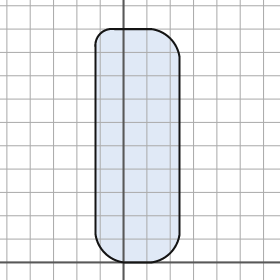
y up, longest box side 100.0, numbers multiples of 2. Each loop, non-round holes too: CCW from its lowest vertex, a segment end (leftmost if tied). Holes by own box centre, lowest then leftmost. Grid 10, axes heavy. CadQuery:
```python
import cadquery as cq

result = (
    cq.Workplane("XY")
    .moveTo(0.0, 0.0)
    .lineTo(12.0, 0.0)
    .threePointArc((20.0, 4.0), (24.0, 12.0))
    .lineTo(24.0, 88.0)
    .threePointArc((20.0, 96.0), (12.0, 100.0))
    .lineTo(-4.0, 100.0)
    .threePointArc((-10.0, 98.0), (-12.0, 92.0))
    .lineTo(-12.0, 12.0)
    .threePointArc((-8.0, 4.0), (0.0, 0.0))
    .close()
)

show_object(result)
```